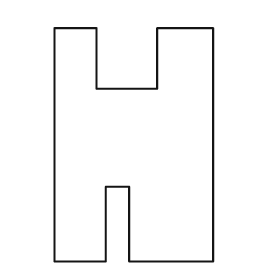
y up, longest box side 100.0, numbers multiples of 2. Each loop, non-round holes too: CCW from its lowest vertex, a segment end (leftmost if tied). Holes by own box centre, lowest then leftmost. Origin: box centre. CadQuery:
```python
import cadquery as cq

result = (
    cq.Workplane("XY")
    .moveTo(-34.0, -50.0)
    .lineTo(-12.0, -50.0)
    .lineTo(-12.0, -18.0)
    .lineTo(-2.0, -18.0)
    .lineTo(-2.0, -50.0)
    .lineTo(34.0, -50.0)
    .lineTo(34.0, 50.0)
    .lineTo(10.0, 50.0)
    .lineTo(10.0, 24.0)
    .lineTo(-16.0, 24.0)
    .lineTo(-16.0, 50.0)
    .lineTo(-34.0, 50.0)
    .close()
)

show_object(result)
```